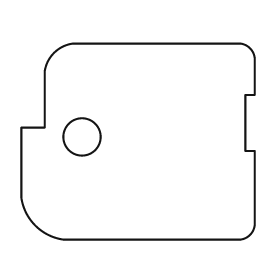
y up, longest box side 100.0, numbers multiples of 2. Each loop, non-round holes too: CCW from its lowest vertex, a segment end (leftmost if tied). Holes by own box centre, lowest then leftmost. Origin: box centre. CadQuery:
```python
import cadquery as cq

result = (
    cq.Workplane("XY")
    .moveTo(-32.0, -42.0)
    .lineTo(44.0, -42.0)
    .threePointArc((48.0, -40.0), (50.0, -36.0))
    .lineTo(50.0, -4.0)
    .lineTo(46.0, -4.0)
    .lineTo(46.0, 20.0)
    .lineTo(50.0, 20.0)
    .lineTo(50.0, 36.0)
    .threePointArc((48.0, 40.0), (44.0, 42.0))
    .lineTo(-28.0, 42.0)
    .threePointArc((-36.0, 38.0), (-40.0, 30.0))
    .lineTo(-40.0, 6.0)
    .lineTo(-50.0, 6.0)
    .lineTo(-50.0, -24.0)
    .threePointArc((-44.0, -36.0), (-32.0, -42.0))
    .close()
    .moveTo(-24.0, 2.0)
    .circle(8.0)
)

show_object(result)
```